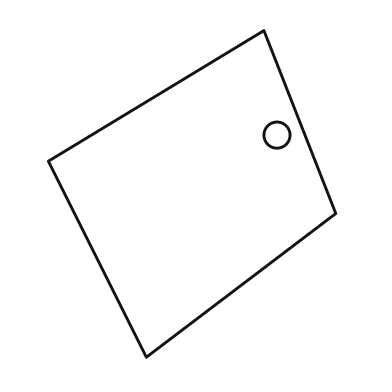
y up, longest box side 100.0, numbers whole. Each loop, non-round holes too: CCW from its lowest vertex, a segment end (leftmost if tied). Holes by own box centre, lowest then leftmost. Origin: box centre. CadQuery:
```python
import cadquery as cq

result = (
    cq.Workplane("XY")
    .moveTo(-14.0, -50.0)
    .lineTo(44.0, -6.0)
    .lineTo(22.0, 50.0)
    .lineTo(-44.0, 10.0)
    .close()
    .moveTo(26.0, 18.0)
    .circle(4.0)
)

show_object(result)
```